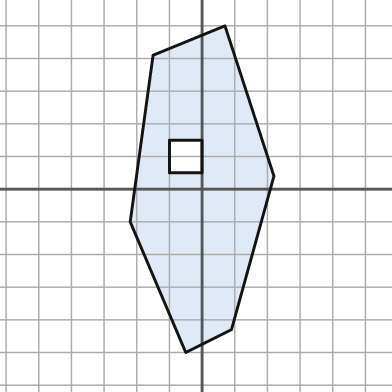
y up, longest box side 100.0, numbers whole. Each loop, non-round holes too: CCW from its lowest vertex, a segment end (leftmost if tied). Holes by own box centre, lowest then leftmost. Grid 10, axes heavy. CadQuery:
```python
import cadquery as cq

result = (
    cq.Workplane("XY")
    .moveTo(-5.0, -50.0)
    .lineTo(9.0, -43.0)
    .lineTo(22.0, 4.0)
    .lineTo(7.0, 50.0)
    .lineTo(-15.0, 41.0)
    .lineTo(-22.0, -10.0)
    .close()
    .moveTo(-10.0, 5.0)
    .lineTo(0.0, 5.0)
    .lineTo(0.0, 15.0)
    .lineTo(-10.0, 15.0)
    .close()
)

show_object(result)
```